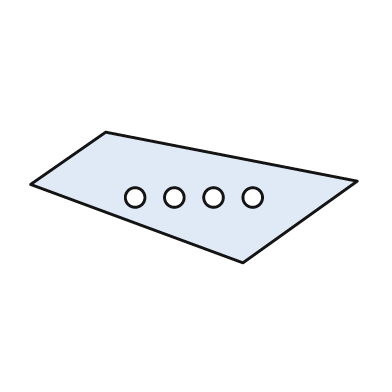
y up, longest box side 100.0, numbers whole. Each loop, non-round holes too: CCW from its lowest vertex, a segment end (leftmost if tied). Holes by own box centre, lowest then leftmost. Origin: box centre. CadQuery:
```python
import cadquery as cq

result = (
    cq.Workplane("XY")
    .moveTo(15.0, -20.0)
    .lineTo(50.0, 5.0)
    .lineTo(-27.0, 20.0)
    .lineTo(-50.0, 4.0)
    .close()
    .moveTo(-18.0, 0.0)
    .circle(3.0)
    .moveTo(-6.0, 0.0)
    .circle(3.0)
    .moveTo(6.0, 0.0)
    .circle(3.0)
    .moveTo(18.0, 0.0)
    .circle(3.0)
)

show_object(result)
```